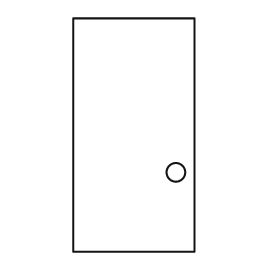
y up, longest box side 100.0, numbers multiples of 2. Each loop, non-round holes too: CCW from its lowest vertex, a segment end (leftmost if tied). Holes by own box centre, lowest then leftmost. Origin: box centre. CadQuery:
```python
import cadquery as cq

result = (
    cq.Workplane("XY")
    .moveTo(-26.0, -50.0)
    .lineTo(26.0, -50.0)
    .lineTo(26.0, 50.0)
    .lineTo(-26.0, 50.0)
    .close()
    .moveTo(18.0, -16.0)
    .circle(4.0)
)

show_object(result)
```